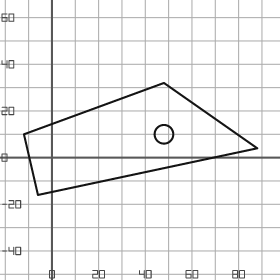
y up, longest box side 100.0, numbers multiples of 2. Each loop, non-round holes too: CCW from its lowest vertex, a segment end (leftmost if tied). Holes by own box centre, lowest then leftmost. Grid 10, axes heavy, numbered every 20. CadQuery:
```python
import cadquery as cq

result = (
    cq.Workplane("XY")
    .moveTo(-6.0, -16.0)
    .lineTo(88.0, 4.0)
    .lineTo(48.0, 32.0)
    .lineTo(-12.0, 10.0)
    .close()
    .moveTo(48.0, 10.0)
    .circle(4.0)
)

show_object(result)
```